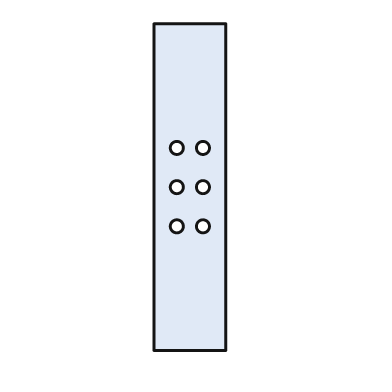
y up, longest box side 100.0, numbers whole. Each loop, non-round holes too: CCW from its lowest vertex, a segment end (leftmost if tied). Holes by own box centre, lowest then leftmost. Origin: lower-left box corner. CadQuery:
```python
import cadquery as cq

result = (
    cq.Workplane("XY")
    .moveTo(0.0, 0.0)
    .lineTo(22.0, 0.0)
    .lineTo(22.0, 100.0)
    .lineTo(0.0, 100.0)
    .close()
    .moveTo(7.0, 38.0)
    .circle(2.0)
    .moveTo(15.0, 38.0)
    .circle(2.0)
    .moveTo(7.0, 50.0)
    .circle(2.0)
    .moveTo(15.0, 50.0)
    .circle(2.0)
    .moveTo(7.0, 62.0)
    .circle(2.0)
    .moveTo(15.0, 62.0)
    .circle(2.0)
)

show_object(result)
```